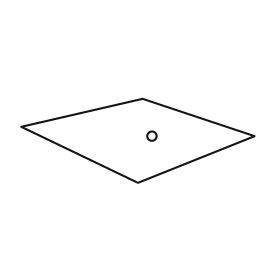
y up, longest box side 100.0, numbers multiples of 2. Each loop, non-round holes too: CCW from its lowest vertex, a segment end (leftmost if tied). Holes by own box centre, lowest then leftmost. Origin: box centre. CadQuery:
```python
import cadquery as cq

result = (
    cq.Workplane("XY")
    .moveTo(0.0, -18.0)
    .lineTo(50.0, 2.0)
    .lineTo(2.0, 18.0)
    .lineTo(-50.0, 6.0)
    .close()
    .moveTo(6.0, 2.0)
    .circle(2.0)
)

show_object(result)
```